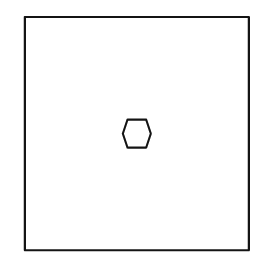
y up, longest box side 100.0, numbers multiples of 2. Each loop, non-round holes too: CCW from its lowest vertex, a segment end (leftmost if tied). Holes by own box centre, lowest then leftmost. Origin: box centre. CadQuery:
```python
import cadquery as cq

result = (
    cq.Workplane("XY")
    .moveTo(-48.0, -50.0)
    .lineTo(48.0, -50.0)
    .lineTo(48.0, 50.0)
    .lineTo(-48.0, 50.0)
    .close()
    .moveTo(-4.0, -6.0)
    .lineTo(4.0, -6.0)
    .lineTo(6.0, 0.0)
    .lineTo(4.0, 6.0)
    .lineTo(-4.0, 6.0)
    .lineTo(-6.0, 0.0)
    .close()
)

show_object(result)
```